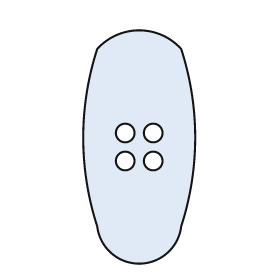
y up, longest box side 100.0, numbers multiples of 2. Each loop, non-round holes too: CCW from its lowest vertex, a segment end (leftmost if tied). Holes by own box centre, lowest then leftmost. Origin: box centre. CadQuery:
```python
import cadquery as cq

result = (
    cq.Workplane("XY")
    .moveTo(-18.0, -34.0)
    .threePointArc((0.0, -50.0), (18.0, -34.0))
    .threePointArc((24.0, 4.0), (18.0, 42.0))
    .threePointArc((0.0, 50.0), (-18.0, 42.0))
    .threePointArc((-24.0, 4.0), (-18.0, -34.0))
    .close()
    .moveTo(-6.0, -6.0)
    .circle(4.0)
    .moveTo(6.0, -6.0)
    .circle(4.0)
    .moveTo(-6.0, 6.0)
    .circle(4.0)
    .moveTo(6.0, 6.0)
    .circle(4.0)
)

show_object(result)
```